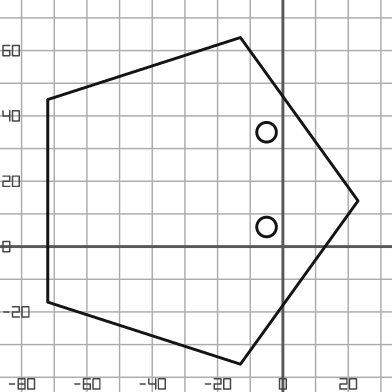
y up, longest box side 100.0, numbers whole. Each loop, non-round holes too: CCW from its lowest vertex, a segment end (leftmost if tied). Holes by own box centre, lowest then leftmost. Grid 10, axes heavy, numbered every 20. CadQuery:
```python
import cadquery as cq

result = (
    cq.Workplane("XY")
    .moveTo(-13.0, -36.0)
    .lineTo(23.0, 14.0)
    .lineTo(-13.0, 64.0)
    .lineTo(-72.0, 45.0)
    .lineTo(-72.0, -17.0)
    .close()
    .moveTo(-5.0, 6.0)
    .circle(3.0)
    .moveTo(-5.0, 35.0)
    .circle(3.0)
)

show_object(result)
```